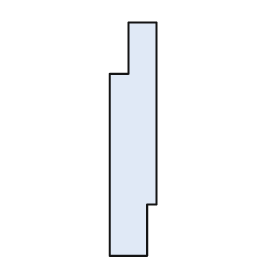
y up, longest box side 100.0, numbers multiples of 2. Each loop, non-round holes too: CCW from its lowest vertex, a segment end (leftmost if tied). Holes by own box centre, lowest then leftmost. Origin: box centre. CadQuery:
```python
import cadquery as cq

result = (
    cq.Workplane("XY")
    .moveTo(-10.0, -50.0)
    .lineTo(6.0, -50.0)
    .lineTo(6.0, -28.0)
    .lineTo(10.0, -28.0)
    .lineTo(10.0, 50.0)
    .lineTo(-2.0, 50.0)
    .lineTo(-2.0, 28.0)
    .lineTo(-10.0, 28.0)
    .close()
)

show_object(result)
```